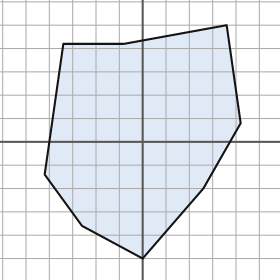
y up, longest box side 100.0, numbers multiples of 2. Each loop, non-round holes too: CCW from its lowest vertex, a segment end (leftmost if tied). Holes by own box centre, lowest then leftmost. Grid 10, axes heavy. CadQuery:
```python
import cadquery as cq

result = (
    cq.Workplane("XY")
    .moveTo(0.0, -50.0)
    .lineTo(26.0, -20.0)
    .lineTo(42.0, 8.0)
    .lineTo(36.0, 50.0)
    .lineTo(-8.0, 42.0)
    .lineTo(-34.0, 42.0)
    .lineTo(-42.0, -14.0)
    .lineTo(-26.0, -36.0)
    .close()
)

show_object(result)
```